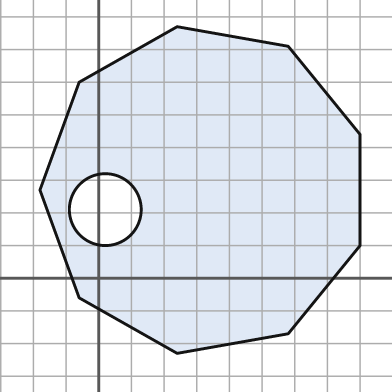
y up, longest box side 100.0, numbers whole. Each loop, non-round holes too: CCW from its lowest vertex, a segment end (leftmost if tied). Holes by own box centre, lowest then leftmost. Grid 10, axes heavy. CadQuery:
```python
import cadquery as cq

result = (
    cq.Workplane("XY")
    .moveTo(24.0, -23.0)
    .lineTo(58.0, -17.0)
    .lineTo(80.0, 10.0)
    .lineTo(80.0, 44.0)
    .lineTo(58.0, 71.0)
    .lineTo(24.0, 77.0)
    .lineTo(-6.0, 60.0)
    .lineTo(-18.0, 27.0)
    .lineTo(-6.0, -6.0)
    .close()
    .moveTo(2.0, 21.0)
    .circle(11.0)
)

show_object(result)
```